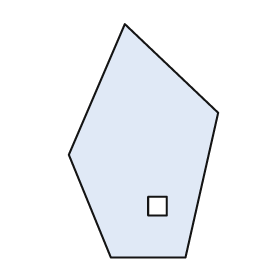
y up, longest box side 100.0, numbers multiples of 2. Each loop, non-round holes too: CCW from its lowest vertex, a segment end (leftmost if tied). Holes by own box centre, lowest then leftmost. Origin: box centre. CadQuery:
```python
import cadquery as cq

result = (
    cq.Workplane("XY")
    .moveTo(-14.0, -50.0)
    .lineTo(18.0, -50.0)
    .lineTo(32.0, 12.0)
    .lineTo(-8.0, 50.0)
    .lineTo(-32.0, -6.0)
    .close()
    .moveTo(2.0, -32.0)
    .lineTo(10.0, -32.0)
    .lineTo(10.0, -24.0)
    .lineTo(2.0, -24.0)
    .close()
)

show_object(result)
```